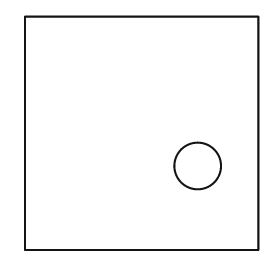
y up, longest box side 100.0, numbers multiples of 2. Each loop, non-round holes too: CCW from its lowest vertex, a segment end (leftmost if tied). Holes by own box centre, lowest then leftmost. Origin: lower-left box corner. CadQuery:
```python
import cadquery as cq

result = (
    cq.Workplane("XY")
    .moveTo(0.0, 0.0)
    .lineTo(100.0, 0.0)
    .lineTo(100.0, 100.0)
    .lineTo(0.0, 100.0)
    .close()
    .moveTo(74.0, 36.0)
    .circle(10.0)
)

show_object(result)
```